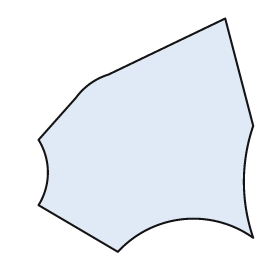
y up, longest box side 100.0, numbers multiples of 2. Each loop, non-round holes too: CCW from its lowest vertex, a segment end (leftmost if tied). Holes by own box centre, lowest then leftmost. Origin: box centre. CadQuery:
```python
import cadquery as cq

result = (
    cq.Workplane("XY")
    .moveTo(-12.0, -50.0)
    .threePointArc((16.0, -36.0), (46.0, -44.0))
    .threePointArc((42.0, -20.0), (46.0, 4.0))
    .lineTo(34.0, 50.0)
    .lineTo(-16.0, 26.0)
    .threePointArc((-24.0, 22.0), (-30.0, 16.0))
    .lineTo(-46.0, -2.0)
    .threePointArc((-42.0, -16.0), (-46.0, -30.0))
    .close()
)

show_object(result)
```